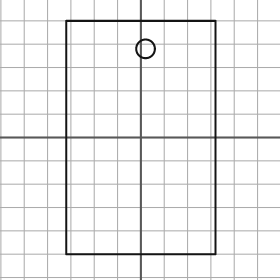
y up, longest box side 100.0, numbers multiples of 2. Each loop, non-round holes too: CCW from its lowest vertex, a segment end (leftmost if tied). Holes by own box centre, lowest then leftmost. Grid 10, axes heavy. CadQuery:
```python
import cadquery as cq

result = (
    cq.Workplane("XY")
    .moveTo(-32.0, -50.0)
    .lineTo(32.0, -50.0)
    .lineTo(32.0, 50.0)
    .lineTo(-32.0, 50.0)
    .close()
    .moveTo(2.0, 38.0)
    .circle(4.0)
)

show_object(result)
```